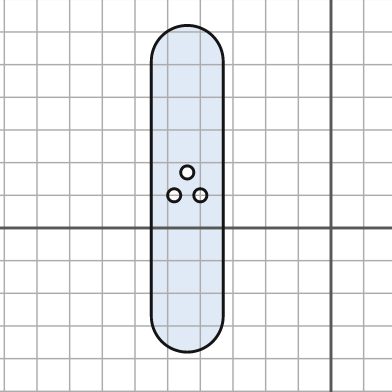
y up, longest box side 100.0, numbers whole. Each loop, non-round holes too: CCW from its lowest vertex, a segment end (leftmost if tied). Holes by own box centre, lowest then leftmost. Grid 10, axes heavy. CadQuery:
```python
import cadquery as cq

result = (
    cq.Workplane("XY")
    .moveTo(-55.0, -27.0)
    .threePointArc((-44.0, -38.0), (-33.0, -27.0))
    .lineTo(-33.0, 51.0)
    .threePointArc((-44.0, 62.0), (-55.0, 51.0))
    .close()
    .moveTo(-48.0, 10.0)
    .circle(2.0)
    .moveTo(-40.0, 10.0)
    .circle(2.0)
    .moveTo(-44.0, 17.0)
    .circle(2.0)
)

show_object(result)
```